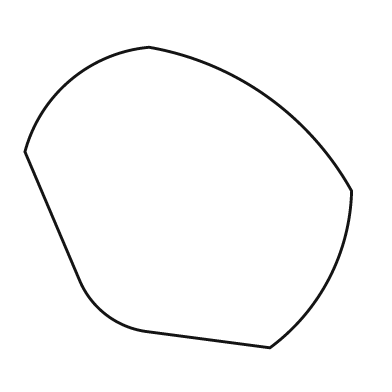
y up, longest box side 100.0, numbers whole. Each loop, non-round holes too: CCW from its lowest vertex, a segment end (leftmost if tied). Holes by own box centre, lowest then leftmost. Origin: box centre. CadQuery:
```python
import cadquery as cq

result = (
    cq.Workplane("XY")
    .moveTo(25.0, -46.0)
    .threePointArc((43.0, -25.0), (50.0, 2.0))
    .threePointArc((24.0, 31.0), (-12.0, 46.0))
    .threePointArc((-36.0, 36.0), (-50.0, 14.0))
    .lineTo(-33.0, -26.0)
    .threePointArc((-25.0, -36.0), (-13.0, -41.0))
    .close()
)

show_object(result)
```